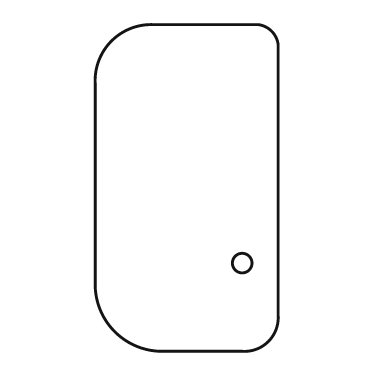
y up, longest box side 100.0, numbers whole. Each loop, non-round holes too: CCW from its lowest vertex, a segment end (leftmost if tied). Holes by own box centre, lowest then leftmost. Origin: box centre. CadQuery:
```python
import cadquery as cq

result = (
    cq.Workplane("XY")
    .moveTo(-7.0, -50.0)
    .lineTo(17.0, -50.0)
    .threePointArc((25.0, -47.0), (28.0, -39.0))
    .lineTo(28.0, 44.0)
    .threePointArc((26.0, 48.0), (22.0, 50.0))
    .lineTo(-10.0, 50.0)
    .threePointArc((-23.0, 45.0), (-28.0, 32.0))
    .lineTo(-28.0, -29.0)
    .threePointArc((-22.0, -44.0), (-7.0, -50.0))
    .close()
    .moveTo(17.0, -23.0)
    .circle(3.0)
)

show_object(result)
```